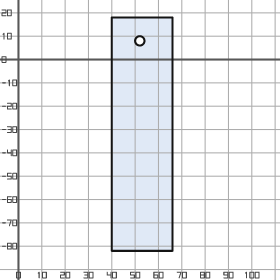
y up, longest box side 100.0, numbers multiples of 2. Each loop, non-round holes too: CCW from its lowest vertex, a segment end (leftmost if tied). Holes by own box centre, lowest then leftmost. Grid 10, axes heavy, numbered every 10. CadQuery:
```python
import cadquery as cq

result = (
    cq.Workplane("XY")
    .moveTo(40.0, -82.0)
    .lineTo(66.0, -82.0)
    .lineTo(66.0, 18.0)
    .lineTo(40.0, 18.0)
    .close()
    .moveTo(52.0, 8.0)
    .circle(2.0)
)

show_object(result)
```